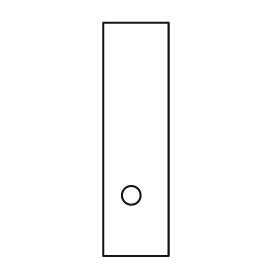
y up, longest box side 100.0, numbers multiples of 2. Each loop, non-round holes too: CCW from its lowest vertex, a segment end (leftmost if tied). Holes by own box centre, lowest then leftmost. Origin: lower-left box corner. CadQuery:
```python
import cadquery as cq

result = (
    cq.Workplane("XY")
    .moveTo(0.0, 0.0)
    .lineTo(28.0, 0.0)
    .lineTo(28.0, 100.0)
    .lineTo(0.0, 100.0)
    .close()
    .moveTo(12.0, 26.0)
    .circle(4.0)
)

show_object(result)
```